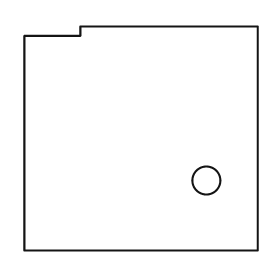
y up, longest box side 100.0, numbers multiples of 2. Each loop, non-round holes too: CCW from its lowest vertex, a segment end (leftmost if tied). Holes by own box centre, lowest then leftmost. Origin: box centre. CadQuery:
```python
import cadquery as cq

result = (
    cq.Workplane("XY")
    .moveTo(-50.0, -48.0)
    .lineTo(50.0, -48.0)
    .lineTo(50.0, 48.0)
    .lineTo(-26.0, 48.0)
    .lineTo(-26.0, 44.0)
    .lineTo(-50.0, 44.0)
    .close()
    .moveTo(28.0, -18.0)
    .circle(6.0)
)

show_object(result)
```